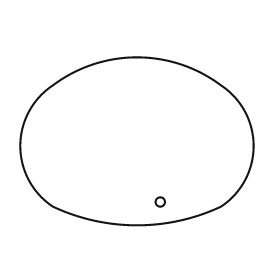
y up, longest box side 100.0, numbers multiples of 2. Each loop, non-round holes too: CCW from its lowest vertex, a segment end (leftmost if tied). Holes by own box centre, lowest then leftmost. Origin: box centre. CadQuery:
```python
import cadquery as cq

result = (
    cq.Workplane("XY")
    .moveTo(-36.0, -28.0)
    .threePointArc((0.0, -36.0), (36.0, -28.0))
    .threePointArc((50.0, -2.0), (36.0, 24.0))
    .threePointArc((0.0, 36.0), (-36.0, 24.0))
    .threePointArc((-50.0, -2.0), (-36.0, -28.0))
    .close()
    .moveTo(10.0, -26.0)
    .circle(2.0)
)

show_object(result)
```